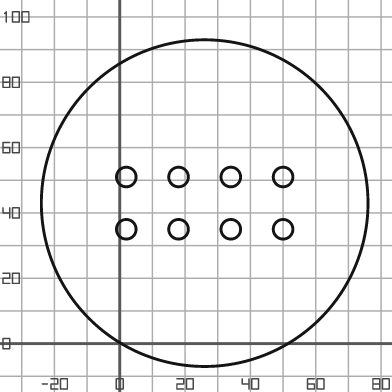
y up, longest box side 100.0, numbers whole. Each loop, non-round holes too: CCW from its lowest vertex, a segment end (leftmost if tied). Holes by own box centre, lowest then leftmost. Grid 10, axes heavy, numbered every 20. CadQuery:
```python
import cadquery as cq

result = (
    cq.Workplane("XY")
    .moveTo(26.0, 43.0)
    .circle(50.0)
    .moveTo(2.0, 35.0)
    .circle(3.0)
    .moveTo(18.0, 35.0)
    .circle(3.0)
    .moveTo(34.0, 35.0)
    .circle(3.0)
    .moveTo(50.0, 35.0)
    .circle(3.0)
    .moveTo(2.0, 51.0)
    .circle(3.0)
    .moveTo(18.0, 51.0)
    .circle(3.0)
    .moveTo(34.0, 51.0)
    .circle(3.0)
    .moveTo(50.0, 51.0)
    .circle(3.0)
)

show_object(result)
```